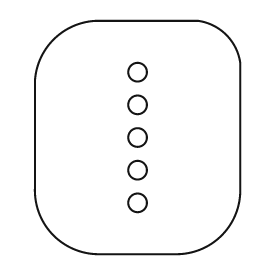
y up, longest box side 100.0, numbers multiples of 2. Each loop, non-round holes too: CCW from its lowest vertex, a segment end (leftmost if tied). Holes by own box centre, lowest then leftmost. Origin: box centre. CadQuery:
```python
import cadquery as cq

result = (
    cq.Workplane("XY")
    .moveTo(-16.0, -50.0)
    .lineTo(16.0, -50.0)
    .threePointArc((36.0, -42.0), (44.0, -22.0))
    .lineTo(44.0, 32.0)
    .threePointArc((38.0, 44.0), (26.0, 50.0))
    .lineTo(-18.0, 50.0)
    .threePointArc((-36.0, 42.0), (-44.0, 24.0))
    .lineTo(-44.0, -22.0)
    .threePointArc((-36.0, -42.0), (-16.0, -50.0))
    .close()
    .moveTo(0.0, -28.0)
    .circle(4.0)
    .moveTo(0.0, -14.0)
    .circle(4.0)
    .moveTo(0.0, 0.0)
    .circle(4.0)
    .moveTo(0.0, 14.0)
    .circle(4.0)
    .moveTo(0.0, 28.0)
    .circle(4.0)
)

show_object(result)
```